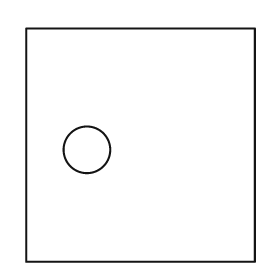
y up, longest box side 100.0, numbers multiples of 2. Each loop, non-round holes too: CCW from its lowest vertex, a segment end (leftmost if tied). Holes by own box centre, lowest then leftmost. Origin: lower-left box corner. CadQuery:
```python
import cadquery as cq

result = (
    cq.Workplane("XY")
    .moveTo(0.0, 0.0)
    .lineTo(98.0, 0.0)
    .lineTo(98.0, 100.0)
    .lineTo(0.0, 100.0)
    .close()
    .moveTo(26.0, 48.0)
    .circle(10.0)
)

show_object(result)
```